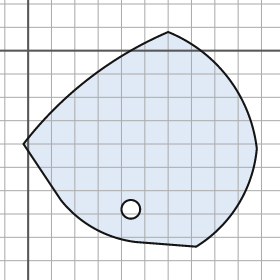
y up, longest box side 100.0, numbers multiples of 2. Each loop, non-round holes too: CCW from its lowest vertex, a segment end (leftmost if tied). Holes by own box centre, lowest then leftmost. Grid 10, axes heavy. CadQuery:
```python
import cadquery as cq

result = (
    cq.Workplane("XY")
    .moveTo(72.0, -84.0)
    .threePointArc((90.0, -66.0), (98.0, -42.0))
    .threePointArc((86.0, -12.0), (60.0, 8.0))
    .threePointArc((26.0, -12.0), (-2.0, -40.0))
    .lineTo(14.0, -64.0)
    .threePointArc((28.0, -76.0), (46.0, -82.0))
    .close()
    .moveTo(44.0, -68.0)
    .circle(4.0)
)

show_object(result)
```